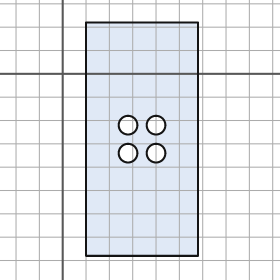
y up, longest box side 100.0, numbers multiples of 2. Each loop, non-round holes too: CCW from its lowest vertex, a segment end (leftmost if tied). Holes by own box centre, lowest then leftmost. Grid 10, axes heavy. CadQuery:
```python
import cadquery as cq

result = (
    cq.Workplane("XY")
    .moveTo(10.0, -78.0)
    .lineTo(58.0, -78.0)
    .lineTo(58.0, 22.0)
    .lineTo(10.0, 22.0)
    .close()
    .moveTo(28.0, -34.0)
    .circle(4.0)
    .moveTo(40.0, -34.0)
    .circle(4.0)
    .moveTo(28.0, -22.0)
    .circle(4.0)
    .moveTo(40.0, -22.0)
    .circle(4.0)
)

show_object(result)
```